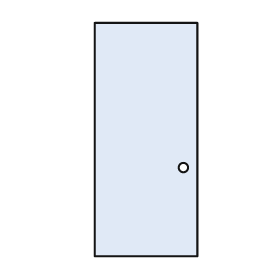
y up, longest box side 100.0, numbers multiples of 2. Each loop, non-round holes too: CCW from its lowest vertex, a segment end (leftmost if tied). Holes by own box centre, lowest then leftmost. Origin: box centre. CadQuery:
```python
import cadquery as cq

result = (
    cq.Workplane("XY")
    .moveTo(-22.0, -50.0)
    .lineTo(22.0, -50.0)
    .lineTo(22.0, 50.0)
    .lineTo(-22.0, 50.0)
    .close()
    .moveTo(16.0, -12.0)
    .circle(2.0)
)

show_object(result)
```